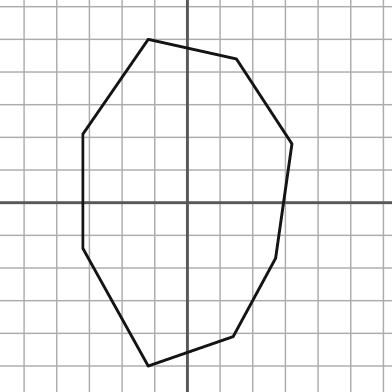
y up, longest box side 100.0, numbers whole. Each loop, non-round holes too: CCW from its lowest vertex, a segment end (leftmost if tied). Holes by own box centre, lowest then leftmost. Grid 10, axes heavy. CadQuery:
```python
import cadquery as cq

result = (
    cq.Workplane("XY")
    .moveTo(-12.0, -50.0)
    .lineTo(14.0, -41.0)
    .lineTo(27.0, -17.0)
    .lineTo(32.0, 18.0)
    .lineTo(15.0, 44.0)
    .lineTo(-12.0, 50.0)
    .lineTo(-32.0, 21.0)
    .lineTo(-32.0, -14.0)
    .close()
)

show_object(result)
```